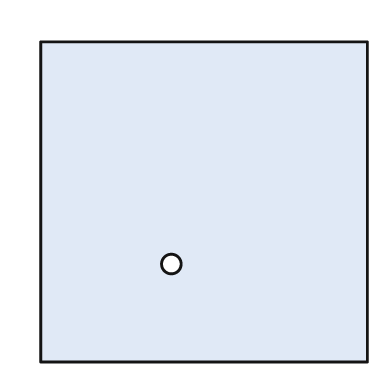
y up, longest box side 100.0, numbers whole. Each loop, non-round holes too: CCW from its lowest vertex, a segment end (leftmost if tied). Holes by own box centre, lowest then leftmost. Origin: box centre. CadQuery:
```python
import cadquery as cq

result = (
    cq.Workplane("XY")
    .moveTo(-50.0, -49.0)
    .lineTo(50.0, -49.0)
    .lineTo(50.0, 49.0)
    .lineTo(-50.0, 49.0)
    .close()
    .moveTo(-10.0, -19.0)
    .circle(3.0)
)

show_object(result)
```